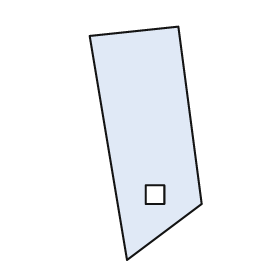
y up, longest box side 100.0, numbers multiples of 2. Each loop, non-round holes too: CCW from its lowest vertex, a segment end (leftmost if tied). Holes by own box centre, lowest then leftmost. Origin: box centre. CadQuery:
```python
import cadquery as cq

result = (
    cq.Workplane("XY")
    .moveTo(-8.0, -50.0)
    .lineTo(24.0, -26.0)
    .lineTo(14.0, 50.0)
    .lineTo(-24.0, 46.0)
    .close()
    .moveTo(0.0, -26.0)
    .lineTo(8.0, -26.0)
    .lineTo(8.0, -18.0)
    .lineTo(0.0, -18.0)
    .close()
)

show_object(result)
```